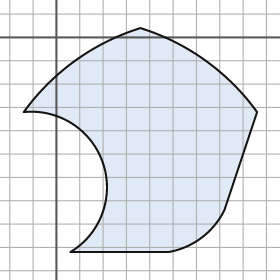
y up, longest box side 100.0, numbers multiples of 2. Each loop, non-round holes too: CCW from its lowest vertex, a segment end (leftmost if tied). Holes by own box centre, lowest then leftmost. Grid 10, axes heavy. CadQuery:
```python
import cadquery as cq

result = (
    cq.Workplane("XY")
    .moveTo(6.0, -92.0)
    .lineTo(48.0, -92.0)
    .threePointArc((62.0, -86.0), (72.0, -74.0))
    .lineTo(86.0, -32.0)
    .threePointArc((64.0, -10.0), (36.0, 4.0))
    .threePointArc((8.0, -10.0), (-14.0, -32.0))
    .threePointArc((20.0, -54.0), (6.0, -92.0))
    .close()
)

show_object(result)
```